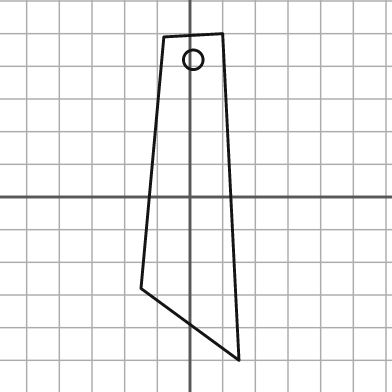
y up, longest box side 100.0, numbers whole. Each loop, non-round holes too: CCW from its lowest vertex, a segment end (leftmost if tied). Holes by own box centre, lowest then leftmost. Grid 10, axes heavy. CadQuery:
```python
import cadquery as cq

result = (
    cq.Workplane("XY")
    .moveTo(15.0, -50.0)
    .lineTo(10.0, 50.0)
    .lineTo(-8.0, 49.0)
    .lineTo(-15.0, -28.0)
    .close()
    .moveTo(1.0, 42.0)
    .circle(3.0)
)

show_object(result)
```